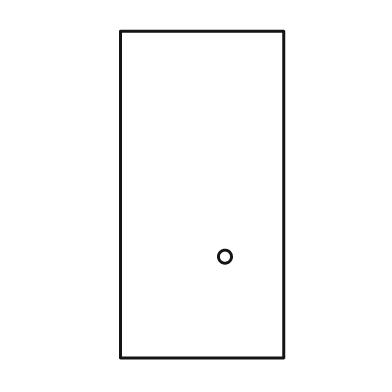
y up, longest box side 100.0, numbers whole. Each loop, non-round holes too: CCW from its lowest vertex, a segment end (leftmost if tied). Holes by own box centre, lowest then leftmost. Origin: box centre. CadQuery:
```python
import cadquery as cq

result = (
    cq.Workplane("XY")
    .moveTo(-25.0, -50.0)
    .lineTo(25.0, -50.0)
    .lineTo(25.0, 50.0)
    .lineTo(-25.0, 50.0)
    .close()
    .moveTo(7.0, -19.0)
    .circle(2.0)
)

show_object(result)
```